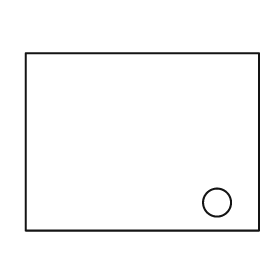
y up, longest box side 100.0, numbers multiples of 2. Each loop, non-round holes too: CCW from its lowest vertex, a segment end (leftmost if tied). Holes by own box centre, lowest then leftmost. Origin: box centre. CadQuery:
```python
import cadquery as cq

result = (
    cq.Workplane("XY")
    .moveTo(-50.0, -38.0)
    .lineTo(50.0, -38.0)
    .lineTo(50.0, 38.0)
    .lineTo(-50.0, 38.0)
    .close()
    .moveTo(32.0, -26.0)
    .circle(6.0)
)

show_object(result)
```